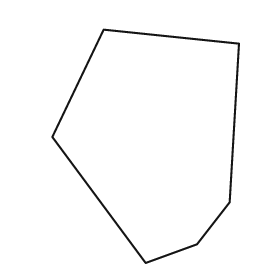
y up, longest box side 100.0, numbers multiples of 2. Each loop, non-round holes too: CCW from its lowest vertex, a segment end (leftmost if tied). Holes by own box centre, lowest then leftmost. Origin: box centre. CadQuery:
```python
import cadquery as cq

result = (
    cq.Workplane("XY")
    .moveTo(0.0, -50.0)
    .lineTo(22.0, -42.0)
    .lineTo(36.0, -24.0)
    .lineTo(40.0, 44.0)
    .lineTo(-18.0, 50.0)
    .lineTo(-40.0, 4.0)
    .close()
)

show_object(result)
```